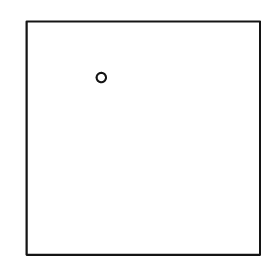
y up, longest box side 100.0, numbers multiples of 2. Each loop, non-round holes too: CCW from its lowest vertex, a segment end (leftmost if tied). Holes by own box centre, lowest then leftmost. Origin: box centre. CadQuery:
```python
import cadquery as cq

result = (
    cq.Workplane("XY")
    .moveTo(-50.0, -50.0)
    .lineTo(50.0, -50.0)
    .lineTo(50.0, 50.0)
    .lineTo(-50.0, 50.0)
    .close()
    .moveTo(-18.0, 26.0)
    .circle(2.0)
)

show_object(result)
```